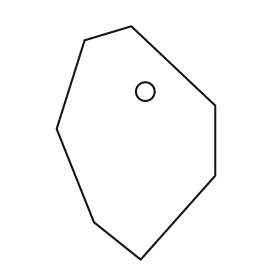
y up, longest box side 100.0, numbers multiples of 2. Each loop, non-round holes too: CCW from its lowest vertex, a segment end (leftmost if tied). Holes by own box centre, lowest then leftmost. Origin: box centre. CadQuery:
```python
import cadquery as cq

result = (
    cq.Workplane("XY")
    .moveTo(2.0, -50.0)
    .lineTo(34.0, -14.0)
    .lineTo(34.0, 16.0)
    .lineTo(-2.0, 50.0)
    .lineTo(-22.0, 44.0)
    .lineTo(-34.0, 6.0)
    .lineTo(-18.0, -34.0)
    .close()
    .moveTo(4.0, 22.0)
    .circle(4.0)
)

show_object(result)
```